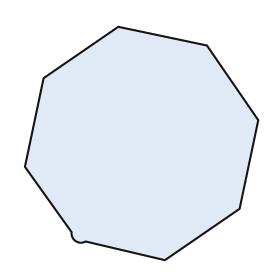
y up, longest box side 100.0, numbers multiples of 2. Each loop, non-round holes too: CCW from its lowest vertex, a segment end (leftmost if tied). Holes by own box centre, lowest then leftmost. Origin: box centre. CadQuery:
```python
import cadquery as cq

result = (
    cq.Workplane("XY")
    .moveTo(10.0, -50.0)
    .lineTo(42.0, -28.0)
    .lineTo(50.0, 10.0)
    .lineTo(28.0, 42.0)
    .lineTo(-10.0, 50.0)
    .lineTo(-42.0, 28.0)
    .lineTo(-50.0, -10.0)
    .lineTo(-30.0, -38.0)
    .threePointArc((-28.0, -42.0), (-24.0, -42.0))
    .close()
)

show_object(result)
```